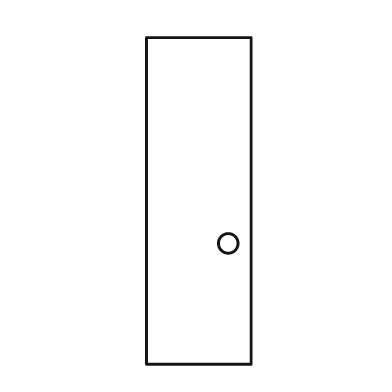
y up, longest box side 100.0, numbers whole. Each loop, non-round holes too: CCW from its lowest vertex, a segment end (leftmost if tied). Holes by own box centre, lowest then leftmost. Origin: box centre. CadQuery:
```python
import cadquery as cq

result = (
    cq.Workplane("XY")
    .moveTo(-16.0, -50.0)
    .lineTo(16.0, -50.0)
    .lineTo(16.0, 50.0)
    .lineTo(-16.0, 50.0)
    .close()
    .moveTo(9.0, -13.0)
    .circle(3.0)
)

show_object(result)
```